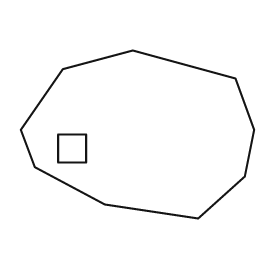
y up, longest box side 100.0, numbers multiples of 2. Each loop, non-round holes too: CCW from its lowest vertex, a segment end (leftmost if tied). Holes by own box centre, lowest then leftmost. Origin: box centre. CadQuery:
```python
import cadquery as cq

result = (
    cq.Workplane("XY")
    .moveTo(26.0, -36.0)
    .lineTo(46.0, -18.0)
    .lineTo(50.0, 2.0)
    .lineTo(42.0, 24.0)
    .lineTo(-2.0, 36.0)
    .lineTo(-32.0, 28.0)
    .lineTo(-50.0, 2.0)
    .lineTo(-44.0, -14.0)
    .lineTo(-14.0, -30.0)
    .close()
    .moveTo(-34.0, -12.0)
    .lineTo(-22.0, -12.0)
    .lineTo(-22.0, 0.0)
    .lineTo(-34.0, 0.0)
    .close()
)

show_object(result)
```